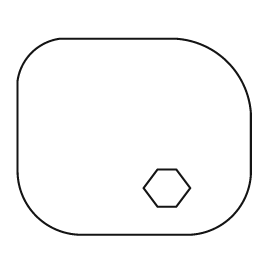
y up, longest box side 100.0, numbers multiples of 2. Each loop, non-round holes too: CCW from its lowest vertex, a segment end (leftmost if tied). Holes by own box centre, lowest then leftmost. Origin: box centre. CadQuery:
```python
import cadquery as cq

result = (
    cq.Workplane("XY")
    .moveTo(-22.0, -42.0)
    .lineTo(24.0, -42.0)
    .threePointArc((42.0, -34.0), (50.0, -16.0))
    .lineTo(50.0, 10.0)
    .threePointArc((40.0, 32.0), (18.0, 42.0))
    .lineTo(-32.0, 42.0)
    .threePointArc((-44.0, 36.0), (-50.0, 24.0))
    .lineTo(-50.0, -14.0)
    .threePointArc((-42.0, -34.0), (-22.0, -42.0))
    .close()
    .moveTo(10.0, -30.0)
    .lineTo(18.0, -30.0)
    .lineTo(24.0, -22.0)
    .lineTo(18.0, -14.0)
    .lineTo(10.0, -14.0)
    .lineTo(4.0, -22.0)
    .close()
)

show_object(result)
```